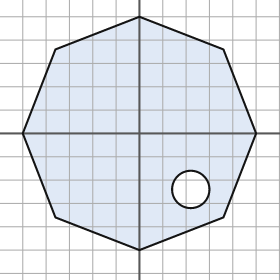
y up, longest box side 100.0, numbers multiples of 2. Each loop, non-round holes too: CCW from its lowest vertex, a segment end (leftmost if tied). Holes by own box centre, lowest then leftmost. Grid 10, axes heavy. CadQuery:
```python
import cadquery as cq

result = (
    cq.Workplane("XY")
    .moveTo(0.0, -50.0)
    .lineTo(36.0, -36.0)
    .lineTo(50.0, 0.0)
    .lineTo(36.0, 36.0)
    .lineTo(0.0, 50.0)
    .lineTo(-36.0, 36.0)
    .lineTo(-50.0, 0.0)
    .lineTo(-36.0, -36.0)
    .close()
    .moveTo(22.0, -24.0)
    .circle(8.0)
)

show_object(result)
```